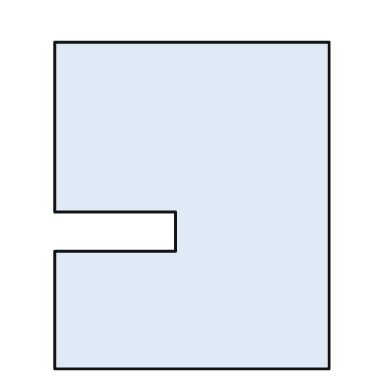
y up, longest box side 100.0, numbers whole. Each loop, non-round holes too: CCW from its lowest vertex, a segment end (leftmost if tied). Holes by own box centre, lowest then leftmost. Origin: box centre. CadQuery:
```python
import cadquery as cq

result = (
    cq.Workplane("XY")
    .moveTo(-42.0, -50.0)
    .lineTo(42.0, -50.0)
    .lineTo(42.0, 50.0)
    .lineTo(-42.0, 50.0)
    .lineTo(-42.0, -2.0)
    .lineTo(-5.0, -2.0)
    .lineTo(-5.0, -14.0)
    .lineTo(-42.0, -14.0)
    .close()
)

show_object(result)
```